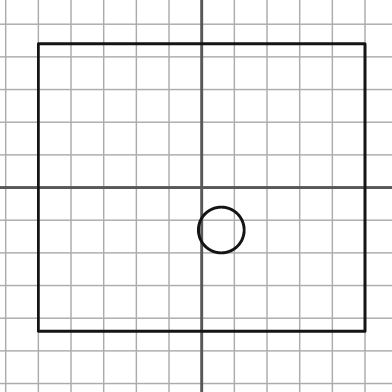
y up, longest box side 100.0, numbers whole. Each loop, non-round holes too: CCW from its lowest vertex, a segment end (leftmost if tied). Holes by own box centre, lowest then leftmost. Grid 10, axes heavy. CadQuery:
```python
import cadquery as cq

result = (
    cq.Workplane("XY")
    .moveTo(-50.0, -44.0)
    .lineTo(50.0, -44.0)
    .lineTo(50.0, 44.0)
    .lineTo(-50.0, 44.0)
    .close()
    .moveTo(6.0, -13.0)
    .circle(7.0)
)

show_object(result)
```